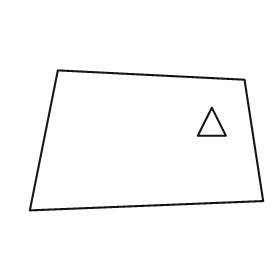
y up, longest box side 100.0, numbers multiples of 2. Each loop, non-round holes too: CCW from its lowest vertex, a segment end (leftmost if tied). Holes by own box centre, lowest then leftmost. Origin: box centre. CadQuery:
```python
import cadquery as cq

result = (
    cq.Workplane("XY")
    .moveTo(-50.0, -30.0)
    .lineTo(50.0, -26.0)
    .lineTo(42.0, 26.0)
    .lineTo(-38.0, 30.0)
    .close()
    .moveTo(22.0, 2.0)
    .lineTo(34.0, 2.0)
    .lineTo(28.0, 14.0)
    .close()
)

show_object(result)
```